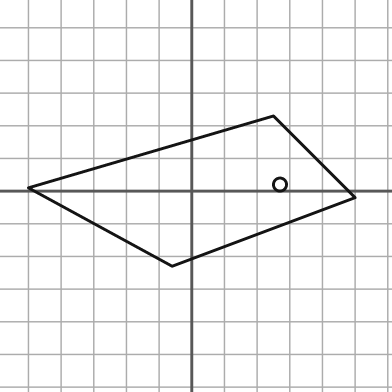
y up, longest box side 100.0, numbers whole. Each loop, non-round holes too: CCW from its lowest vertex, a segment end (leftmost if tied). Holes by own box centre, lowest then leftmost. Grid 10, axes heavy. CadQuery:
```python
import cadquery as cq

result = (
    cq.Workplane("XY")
    .moveTo(-6.0, -23.0)
    .lineTo(50.0, -2.0)
    .lineTo(25.0, 23.0)
    .lineTo(-50.0, 1.0)
    .close()
    .moveTo(27.0, 2.0)
    .circle(2.0)
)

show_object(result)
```